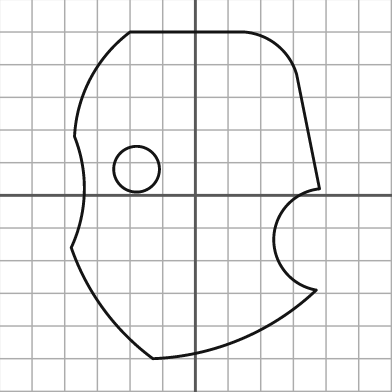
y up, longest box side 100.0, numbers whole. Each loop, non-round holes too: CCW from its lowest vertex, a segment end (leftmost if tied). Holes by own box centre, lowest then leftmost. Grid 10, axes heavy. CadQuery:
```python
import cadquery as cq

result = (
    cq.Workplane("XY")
    .moveTo(-13.0, -50.0)
    .threePointArc((14.0, -44.0), (37.0, -29.0))
    .threePointArc((24.0, -13.0), (38.0, 2.0))
    .lineTo(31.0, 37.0)
    .threePointArc((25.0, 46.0), (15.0, 50.0))
    .lineTo(-20.0, 50.0)
    .threePointArc((-32.0, 36.0), (-37.0, 18.0))
    .threePointArc((-34.0, 1.0), (-38.0, -16.0))
    .threePointArc((-28.0, -35.0), (-13.0, -50.0))
    .close()
    .moveTo(-18.0, 8.0)
    .circle(7.0)
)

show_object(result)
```